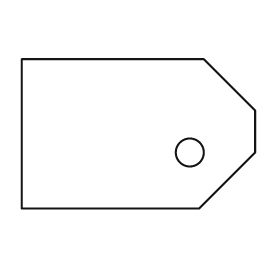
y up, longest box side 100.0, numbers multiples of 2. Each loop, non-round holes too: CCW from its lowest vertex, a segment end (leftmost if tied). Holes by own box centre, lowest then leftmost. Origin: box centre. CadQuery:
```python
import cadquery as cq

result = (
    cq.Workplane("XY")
    .moveTo(-50.0, -32.0)
    .lineTo(26.0, -32.0)
    .lineTo(50.0, -8.0)
    .lineTo(50.0, 10.0)
    .lineTo(28.0, 32.0)
    .lineTo(-50.0, 32.0)
    .close()
    .moveTo(22.0, -8.0)
    .circle(6.0)
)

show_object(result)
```